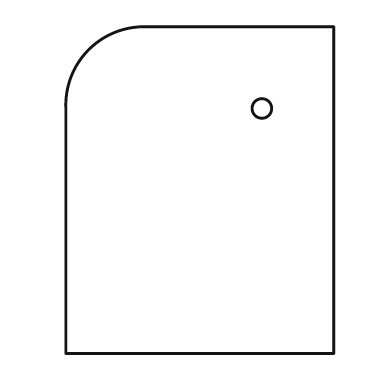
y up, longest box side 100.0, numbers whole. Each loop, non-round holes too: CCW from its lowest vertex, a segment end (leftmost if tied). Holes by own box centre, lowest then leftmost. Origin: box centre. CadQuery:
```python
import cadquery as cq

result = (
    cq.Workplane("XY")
    .moveTo(-41.0, -50.0)
    .lineTo(41.0, -50.0)
    .lineTo(41.0, 50.0)
    .lineTo(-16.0, 50.0)
    .threePointArc((-34.0, 43.0), (-41.0, 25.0))
    .close()
    .moveTo(19.0, 25.0)
    .circle(3.0)
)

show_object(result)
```